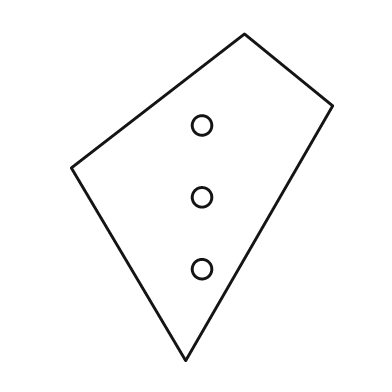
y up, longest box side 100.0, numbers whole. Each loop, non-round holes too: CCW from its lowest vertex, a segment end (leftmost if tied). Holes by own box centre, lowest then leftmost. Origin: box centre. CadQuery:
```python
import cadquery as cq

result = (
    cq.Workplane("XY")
    .moveTo(-5.0, -50.0)
    .lineTo(40.0, 28.0)
    .lineTo(13.0, 50.0)
    .lineTo(-40.0, 9.0)
    .close()
    .moveTo(0.0, -22.0)
    .circle(3.0)
    .moveTo(0.0, 0.0)
    .circle(3.0)
    .moveTo(0.0, 22.0)
    .circle(3.0)
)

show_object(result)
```